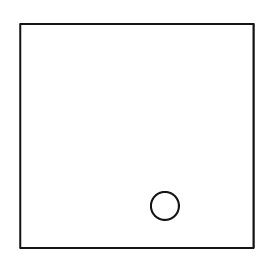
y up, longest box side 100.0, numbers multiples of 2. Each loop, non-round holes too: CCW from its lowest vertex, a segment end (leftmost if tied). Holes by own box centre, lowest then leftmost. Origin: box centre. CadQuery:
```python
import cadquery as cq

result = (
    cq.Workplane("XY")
    .moveTo(-50.0, -48.0)
    .lineTo(50.0, -48.0)
    .lineTo(50.0, 48.0)
    .lineTo(-50.0, 48.0)
    .close()
    .moveTo(12.0, -30.0)
    .circle(6.0)
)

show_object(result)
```